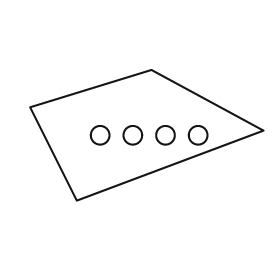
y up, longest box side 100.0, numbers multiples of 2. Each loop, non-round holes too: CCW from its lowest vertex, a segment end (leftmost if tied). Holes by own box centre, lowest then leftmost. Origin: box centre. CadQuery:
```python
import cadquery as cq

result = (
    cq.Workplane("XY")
    .moveTo(-30.0, -28.0)
    .lineTo(50.0, 2.0)
    .lineTo(2.0, 28.0)
    .lineTo(-50.0, 12.0)
    .close()
    .moveTo(-20.0, 0.0)
    .circle(4.0)
    .moveTo(-6.0, 0.0)
    .circle(4.0)
    .moveTo(8.0, 0.0)
    .circle(4.0)
    .moveTo(22.0, 0.0)
    .circle(4.0)
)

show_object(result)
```